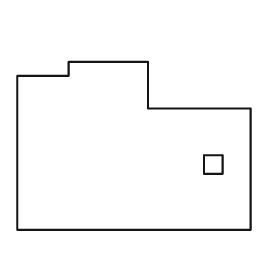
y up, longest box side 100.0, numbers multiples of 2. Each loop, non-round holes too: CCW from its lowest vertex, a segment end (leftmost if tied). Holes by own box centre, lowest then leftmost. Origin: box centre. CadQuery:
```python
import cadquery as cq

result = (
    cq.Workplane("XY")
    .moveTo(-50.0, -36.0)
    .lineTo(50.0, -36.0)
    .lineTo(50.0, 16.0)
    .lineTo(6.0, 16.0)
    .lineTo(6.0, 36.0)
    .lineTo(-28.0, 36.0)
    .lineTo(-28.0, 30.0)
    .lineTo(-50.0, 30.0)
    .close()
    .moveTo(30.0, -12.0)
    .lineTo(38.0, -12.0)
    .lineTo(38.0, -4.0)
    .lineTo(30.0, -4.0)
    .close()
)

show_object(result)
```